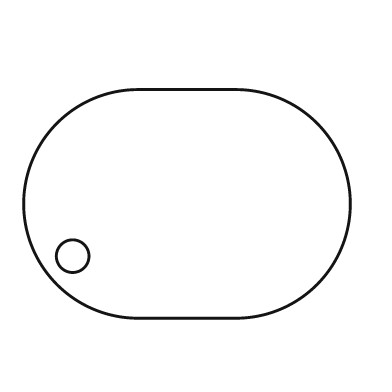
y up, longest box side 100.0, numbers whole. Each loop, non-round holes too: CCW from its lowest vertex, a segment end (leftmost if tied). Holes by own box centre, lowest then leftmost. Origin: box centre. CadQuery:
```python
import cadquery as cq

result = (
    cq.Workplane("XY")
    .moveTo(-15.0, -35.0)
    .lineTo(15.0, -35.0)
    .threePointArc((50.0, 0.0), (15.0, 35.0))
    .lineTo(-15.0, 35.0)
    .threePointArc((-50.0, 0.0), (-15.0, -35.0))
    .close()
    .moveTo(-35.0, -16.0)
    .circle(5.0)
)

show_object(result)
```